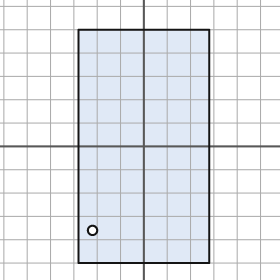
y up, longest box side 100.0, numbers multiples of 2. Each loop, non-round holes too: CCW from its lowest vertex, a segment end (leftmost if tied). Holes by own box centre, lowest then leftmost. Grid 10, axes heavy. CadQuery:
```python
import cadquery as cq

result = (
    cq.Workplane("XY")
    .moveTo(-28.0, -50.0)
    .lineTo(28.0, -50.0)
    .lineTo(28.0, 50.0)
    .lineTo(-28.0, 50.0)
    .close()
    .moveTo(-22.0, -36.0)
    .circle(2.0)
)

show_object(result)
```